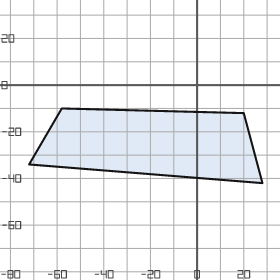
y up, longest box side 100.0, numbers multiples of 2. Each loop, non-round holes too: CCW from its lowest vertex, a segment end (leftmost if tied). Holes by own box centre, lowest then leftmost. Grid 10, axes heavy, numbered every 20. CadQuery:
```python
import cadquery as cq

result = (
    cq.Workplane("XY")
    .moveTo(28.0, -42.0)
    .lineTo(20.0, -12.0)
    .lineTo(-58.0, -10.0)
    .lineTo(-72.0, -34.0)
    .close()
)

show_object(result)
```